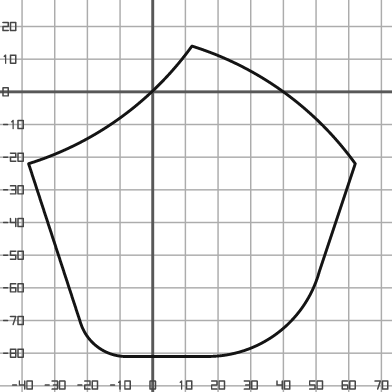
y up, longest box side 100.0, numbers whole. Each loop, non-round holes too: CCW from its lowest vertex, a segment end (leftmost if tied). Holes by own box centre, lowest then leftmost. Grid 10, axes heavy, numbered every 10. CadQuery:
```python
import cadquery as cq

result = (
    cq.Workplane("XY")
    .moveTo(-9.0, -81.0)
    .lineTo(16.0, -81.0)
    .threePointArc((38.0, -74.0), (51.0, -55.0))
    .lineTo(62.0, -22.0)
    .threePointArc((40.0, 0.0), (12.0, 14.0))
    .threePointArc((-10.0, -8.0), (-38.0, -22.0))
    .lineTo(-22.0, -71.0)
    .threePointArc((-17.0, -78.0), (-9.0, -81.0))
    .close()
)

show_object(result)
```